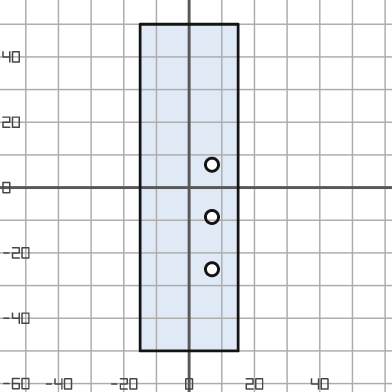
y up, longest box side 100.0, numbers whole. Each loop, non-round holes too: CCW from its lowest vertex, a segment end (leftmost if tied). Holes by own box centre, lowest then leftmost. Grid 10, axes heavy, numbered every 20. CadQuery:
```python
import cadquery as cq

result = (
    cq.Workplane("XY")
    .moveTo(-15.0, -50.0)
    .lineTo(15.0, -50.0)
    .lineTo(15.0, 50.0)
    .lineTo(-15.0, 50.0)
    .close()
    .moveTo(7.0, -25.0)
    .circle(2.0)
    .moveTo(7.0, -9.0)
    .circle(2.0)
    .moveTo(7.0, 7.0)
    .circle(2.0)
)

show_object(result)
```